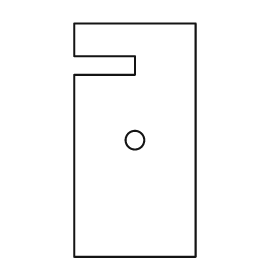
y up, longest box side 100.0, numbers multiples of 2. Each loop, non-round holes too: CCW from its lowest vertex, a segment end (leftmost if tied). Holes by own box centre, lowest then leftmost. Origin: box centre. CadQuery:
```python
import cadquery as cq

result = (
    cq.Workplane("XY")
    .moveTo(-26.0, -50.0)
    .lineTo(26.0, -50.0)
    .lineTo(26.0, 50.0)
    .lineTo(-26.0, 50.0)
    .lineTo(-26.0, 36.0)
    .lineTo(0.0, 36.0)
    .lineTo(0.0, 28.0)
    .lineTo(-26.0, 28.0)
    .close()
    .moveTo(0.0, 0.0)
    .circle(4.0)
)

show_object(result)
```